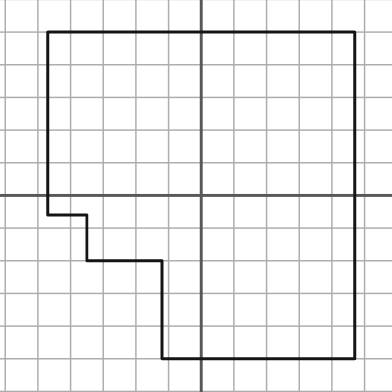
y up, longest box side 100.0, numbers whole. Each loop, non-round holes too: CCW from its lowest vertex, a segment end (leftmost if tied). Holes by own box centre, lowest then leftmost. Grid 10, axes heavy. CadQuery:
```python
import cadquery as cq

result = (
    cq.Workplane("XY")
    .moveTo(-12.0, -50.0)
    .lineTo(47.0, -50.0)
    .lineTo(47.0, 50.0)
    .lineTo(-47.0, 50.0)
    .lineTo(-47.0, -6.0)
    .lineTo(-35.0, -6.0)
    .lineTo(-35.0, -20.0)
    .lineTo(-12.0, -20.0)
    .close()
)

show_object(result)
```